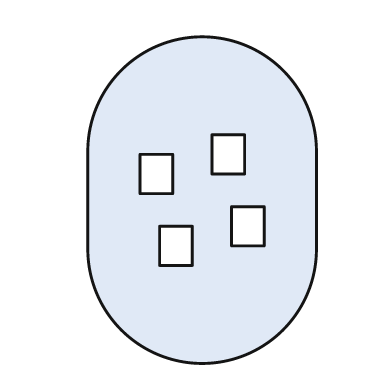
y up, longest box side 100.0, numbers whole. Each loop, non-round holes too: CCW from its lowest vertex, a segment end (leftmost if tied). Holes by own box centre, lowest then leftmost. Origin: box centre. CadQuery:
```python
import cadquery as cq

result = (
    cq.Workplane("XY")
    .moveTo(-35.0, -15.0)
    .threePointArc((0.0, -50.0), (35.0, -15.0))
    .lineTo(35.0, 15.0)
    .threePointArc((0.0, 50.0), (-35.0, 15.0))
    .close()
    .moveTo(-13.0, -20.0)
    .lineTo(-3.0, -20.0)
    .lineTo(-3.0, -8.0)
    .lineTo(-13.0, -8.0)
    .close()
    .moveTo(9.0, -14.0)
    .lineTo(19.0, -14.0)
    .lineTo(19.0, -2.0)
    .lineTo(9.0, -2.0)
    .close()
    .moveTo(-19.0, 2.0)
    .lineTo(-9.0, 2.0)
    .lineTo(-9.0, 14.0)
    .lineTo(-19.0, 14.0)
    .close()
    .moveTo(3.0, 8.0)
    .lineTo(13.0, 8.0)
    .lineTo(13.0, 20.0)
    .lineTo(3.0, 20.0)
    .close()
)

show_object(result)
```